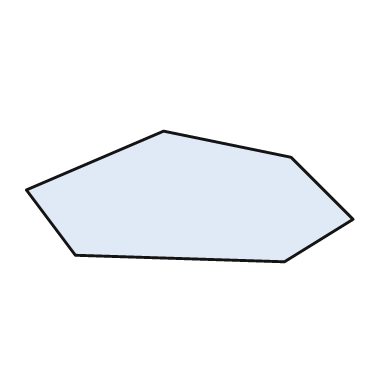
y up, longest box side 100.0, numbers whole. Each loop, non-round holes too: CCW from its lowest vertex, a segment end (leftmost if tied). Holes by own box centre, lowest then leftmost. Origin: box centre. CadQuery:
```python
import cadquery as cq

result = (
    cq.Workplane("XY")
    .moveTo(29.0, -20.0)
    .lineTo(50.0, -7.0)
    .lineTo(31.0, 12.0)
    .lineTo(-8.0, 20.0)
    .lineTo(-50.0, 2.0)
    .lineTo(-35.0, -18.0)
    .close()
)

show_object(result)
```